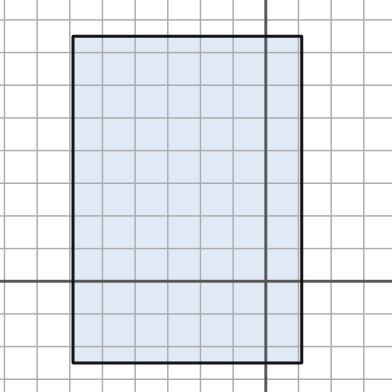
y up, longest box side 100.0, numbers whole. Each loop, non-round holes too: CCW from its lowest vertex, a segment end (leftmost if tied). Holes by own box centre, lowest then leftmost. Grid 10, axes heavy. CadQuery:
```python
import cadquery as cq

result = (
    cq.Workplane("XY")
    .moveTo(-59.0, -25.0)
    .lineTo(11.0, -25.0)
    .lineTo(11.0, 75.0)
    .lineTo(-59.0, 75.0)
    .close()
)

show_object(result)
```